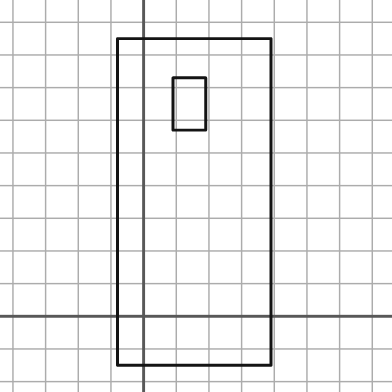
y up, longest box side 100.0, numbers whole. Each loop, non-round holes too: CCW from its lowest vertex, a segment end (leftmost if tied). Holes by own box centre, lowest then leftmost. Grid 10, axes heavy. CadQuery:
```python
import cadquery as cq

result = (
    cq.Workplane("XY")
    .moveTo(-8.0, -15.0)
    .lineTo(39.0, -15.0)
    .lineTo(39.0, 85.0)
    .lineTo(-8.0, 85.0)
    .close()
    .moveTo(9.0, 57.0)
    .lineTo(19.0, 57.0)
    .lineTo(19.0, 73.0)
    .lineTo(9.0, 73.0)
    .close()
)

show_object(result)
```